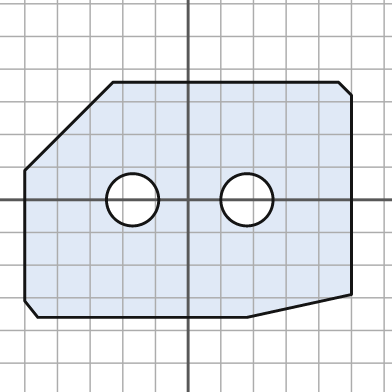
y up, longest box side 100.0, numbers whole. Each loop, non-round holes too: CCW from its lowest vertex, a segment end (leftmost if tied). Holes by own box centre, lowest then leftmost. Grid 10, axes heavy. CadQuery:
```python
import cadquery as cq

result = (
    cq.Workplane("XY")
    .moveTo(-46.0, -36.0)
    .lineTo(18.0, -36.0)
    .lineTo(50.0, -29.0)
    .lineTo(50.0, 32.0)
    .lineTo(46.0, 36.0)
    .lineTo(-23.0, 36.0)
    .lineTo(-50.0, 9.0)
    .lineTo(-50.0, -31.0)
    .close()
    .moveTo(-17.0, 0.0)
    .circle(8.0)
    .moveTo(18.0, 0.0)
    .circle(8.0)
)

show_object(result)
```